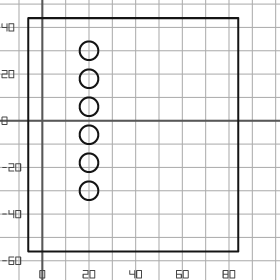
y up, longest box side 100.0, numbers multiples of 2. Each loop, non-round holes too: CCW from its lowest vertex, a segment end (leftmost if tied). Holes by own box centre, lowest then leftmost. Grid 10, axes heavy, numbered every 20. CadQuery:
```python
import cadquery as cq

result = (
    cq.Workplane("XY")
    .moveTo(-6.0, -56.0)
    .lineTo(84.0, -56.0)
    .lineTo(84.0, 44.0)
    .lineTo(-6.0, 44.0)
    .close()
    .moveTo(20.0, -30.0)
    .circle(4.0)
    .moveTo(20.0, -18.0)
    .circle(4.0)
    .moveTo(20.0, -6.0)
    .circle(4.0)
    .moveTo(20.0, 6.0)
    .circle(4.0)
    .moveTo(20.0, 18.0)
    .circle(4.0)
    .moveTo(20.0, 30.0)
    .circle(4.0)
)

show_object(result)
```